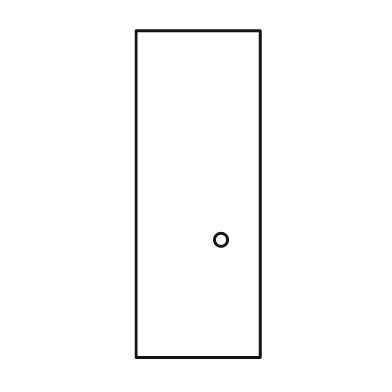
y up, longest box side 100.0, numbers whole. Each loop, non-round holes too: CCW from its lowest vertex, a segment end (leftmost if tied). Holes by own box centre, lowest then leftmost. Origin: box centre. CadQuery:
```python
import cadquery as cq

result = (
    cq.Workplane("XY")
    .moveTo(-19.0, -50.0)
    .lineTo(19.0, -50.0)
    .lineTo(19.0, 50.0)
    .lineTo(-19.0, 50.0)
    .close()
    .moveTo(7.0, -14.0)
    .circle(2.0)
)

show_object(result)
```